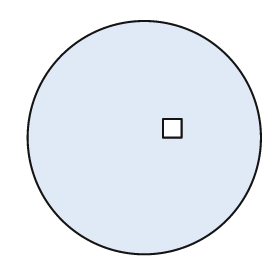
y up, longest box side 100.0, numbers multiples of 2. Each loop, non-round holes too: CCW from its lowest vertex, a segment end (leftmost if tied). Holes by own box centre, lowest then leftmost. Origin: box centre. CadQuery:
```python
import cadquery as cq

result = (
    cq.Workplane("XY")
    .moveTo(0.0, 0.0)
    .circle(50.0)
    .moveTo(8.0, 0.0)
    .lineTo(16.0, 0.0)
    .lineTo(16.0, 8.0)
    .lineTo(8.0, 8.0)
    .close()
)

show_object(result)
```